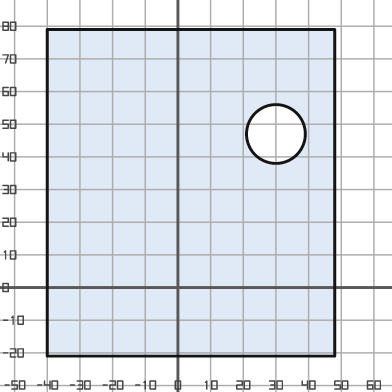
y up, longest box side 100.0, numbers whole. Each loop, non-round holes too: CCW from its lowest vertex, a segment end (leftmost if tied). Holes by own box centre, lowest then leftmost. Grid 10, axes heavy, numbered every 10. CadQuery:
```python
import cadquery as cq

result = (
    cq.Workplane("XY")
    .moveTo(-40.0, -21.0)
    .lineTo(48.0, -21.0)
    .lineTo(48.0, 79.0)
    .lineTo(-40.0, 79.0)
    .close()
    .moveTo(30.0, 47.0)
    .circle(9.0)
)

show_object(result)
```